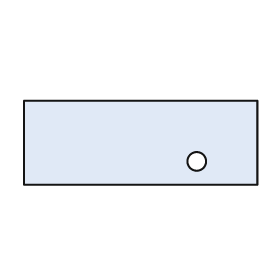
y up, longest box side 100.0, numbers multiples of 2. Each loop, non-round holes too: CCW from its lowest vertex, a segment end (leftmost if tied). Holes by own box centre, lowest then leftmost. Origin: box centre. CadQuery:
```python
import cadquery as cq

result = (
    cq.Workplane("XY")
    .moveTo(-50.0, -18.0)
    .lineTo(50.0, -18.0)
    .lineTo(50.0, 18.0)
    .lineTo(-50.0, 18.0)
    .close()
    .moveTo(24.0, -8.0)
    .circle(4.0)
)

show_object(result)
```